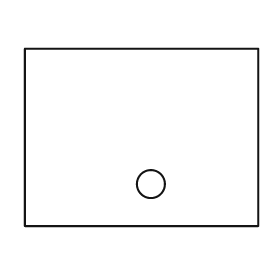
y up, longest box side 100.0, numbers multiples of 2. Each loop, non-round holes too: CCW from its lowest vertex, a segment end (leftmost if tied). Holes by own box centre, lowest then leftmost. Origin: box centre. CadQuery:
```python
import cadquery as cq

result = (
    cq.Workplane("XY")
    .moveTo(-50.0, -38.0)
    .lineTo(50.0, -38.0)
    .lineTo(50.0, 38.0)
    .lineTo(-50.0, 38.0)
    .close()
    .moveTo(4.0, -20.0)
    .circle(6.0)
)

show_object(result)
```